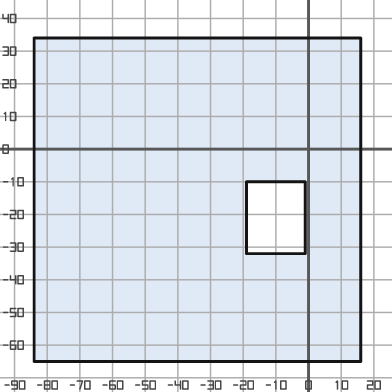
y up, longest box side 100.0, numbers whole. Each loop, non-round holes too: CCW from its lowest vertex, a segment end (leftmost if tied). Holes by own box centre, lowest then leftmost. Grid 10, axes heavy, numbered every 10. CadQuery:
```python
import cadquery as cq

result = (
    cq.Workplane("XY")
    .moveTo(-84.0, -65.0)
    .lineTo(16.0, -65.0)
    .lineTo(16.0, 34.0)
    .lineTo(-84.0, 34.0)
    .close()
    .moveTo(-19.0, -32.0)
    .lineTo(-1.0, -32.0)
    .lineTo(-1.0, -10.0)
    .lineTo(-19.0, -10.0)
    .close()
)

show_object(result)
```